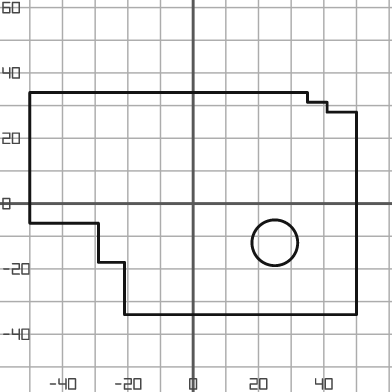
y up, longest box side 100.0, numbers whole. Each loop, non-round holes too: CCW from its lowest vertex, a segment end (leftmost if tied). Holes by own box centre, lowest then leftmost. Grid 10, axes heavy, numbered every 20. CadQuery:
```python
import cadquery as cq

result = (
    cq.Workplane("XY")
    .moveTo(-21.0, -34.0)
    .lineTo(50.0, -34.0)
    .lineTo(50.0, 28.0)
    .lineTo(41.0, 28.0)
    .lineTo(41.0, 31.0)
    .lineTo(35.0, 31.0)
    .lineTo(35.0, 34.0)
    .lineTo(-50.0, 34.0)
    .lineTo(-50.0, -6.0)
    .lineTo(-29.0, -6.0)
    .lineTo(-29.0, -18.0)
    .lineTo(-21.0, -18.0)
    .close()
    .moveTo(25.0, -12.0)
    .circle(7.0)
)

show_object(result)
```